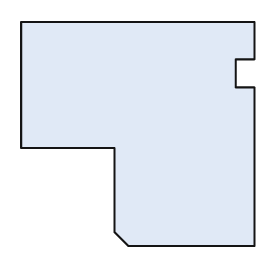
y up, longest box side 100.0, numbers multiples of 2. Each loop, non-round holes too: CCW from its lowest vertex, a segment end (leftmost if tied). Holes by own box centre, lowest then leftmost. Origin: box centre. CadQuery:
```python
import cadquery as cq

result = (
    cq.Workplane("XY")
    .moveTo(-4.0, -48.0)
    .lineTo(50.0, -48.0)
    .lineTo(50.0, 20.0)
    .lineTo(42.0, 20.0)
    .lineTo(42.0, 32.0)
    .lineTo(50.0, 32.0)
    .lineTo(50.0, 48.0)
    .lineTo(-50.0, 48.0)
    .lineTo(-50.0, -6.0)
    .lineTo(-10.0, -6.0)
    .lineTo(-10.0, -42.0)
    .close()
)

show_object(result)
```